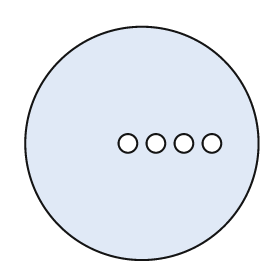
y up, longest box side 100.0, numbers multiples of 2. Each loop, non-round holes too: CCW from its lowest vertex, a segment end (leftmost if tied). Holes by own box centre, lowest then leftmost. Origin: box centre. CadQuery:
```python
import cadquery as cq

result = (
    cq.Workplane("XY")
    .moveTo(0.0, 0.0)
    .circle(50.0)
    .moveTo(-6.0, 0.0)
    .circle(4.0)
    .moveTo(6.0, 0.0)
    .circle(4.0)
    .moveTo(18.0, 0.0)
    .circle(4.0)
    .moveTo(30.0, 0.0)
    .circle(4.0)
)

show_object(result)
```